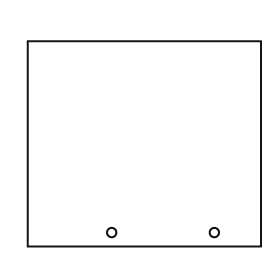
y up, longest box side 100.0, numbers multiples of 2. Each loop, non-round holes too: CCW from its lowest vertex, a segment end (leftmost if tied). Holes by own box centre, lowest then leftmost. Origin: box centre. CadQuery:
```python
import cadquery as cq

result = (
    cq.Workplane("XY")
    .moveTo(-50.0, -44.0)
    .lineTo(50.0, -44.0)
    .lineTo(50.0, 44.0)
    .lineTo(-50.0, 44.0)
    .close()
    .moveTo(-14.0, -38.0)
    .circle(2.0)
    .moveTo(30.0, -38.0)
    .circle(2.0)
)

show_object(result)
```